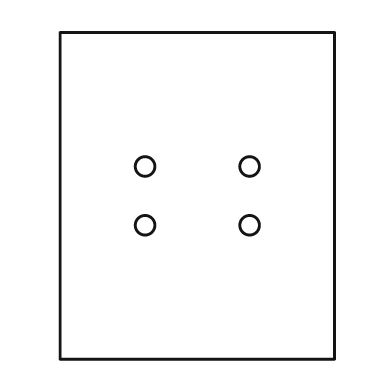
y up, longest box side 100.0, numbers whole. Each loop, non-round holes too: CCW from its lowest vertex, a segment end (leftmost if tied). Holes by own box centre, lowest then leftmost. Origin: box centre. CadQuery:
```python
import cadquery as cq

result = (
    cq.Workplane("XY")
    .moveTo(-42.0, -50.0)
    .lineTo(42.0, -50.0)
    .lineTo(42.0, 50.0)
    .lineTo(-42.0, 50.0)
    .close()
    .moveTo(-16.0, -9.0)
    .circle(3.0)
    .moveTo(16.0, -9.0)
    .circle(3.0)
    .moveTo(-16.0, 9.0)
    .circle(3.0)
    .moveTo(16.0, 9.0)
    .circle(3.0)
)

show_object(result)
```